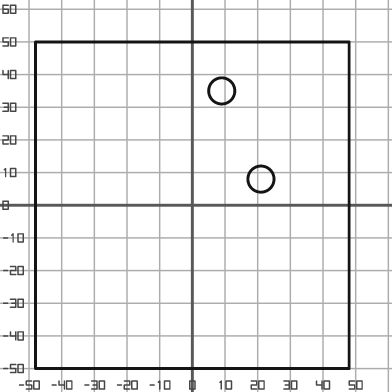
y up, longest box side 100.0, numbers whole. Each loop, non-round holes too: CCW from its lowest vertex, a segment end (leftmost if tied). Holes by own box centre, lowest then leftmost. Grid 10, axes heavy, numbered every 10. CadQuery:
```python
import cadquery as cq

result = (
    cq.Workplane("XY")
    .moveTo(-48.0, -50.0)
    .lineTo(48.0, -50.0)
    .lineTo(48.0, 50.0)
    .lineTo(-48.0, 50.0)
    .close()
    .moveTo(21.0, 8.0)
    .circle(4.0)
    .moveTo(9.0, 35.0)
    .circle(4.0)
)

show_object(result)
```